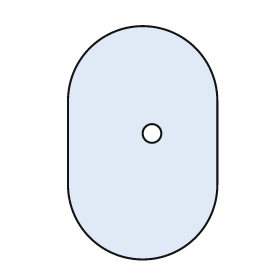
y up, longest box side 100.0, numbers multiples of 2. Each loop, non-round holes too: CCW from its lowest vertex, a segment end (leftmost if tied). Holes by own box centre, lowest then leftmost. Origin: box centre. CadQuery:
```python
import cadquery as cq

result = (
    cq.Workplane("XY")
    .moveTo(-32.0, -18.0)
    .threePointArc((0.0, -50.0), (32.0, -18.0))
    .lineTo(32.0, 18.0)
    .threePointArc((0.0, 50.0), (-32.0, 18.0))
    .close()
    .moveTo(4.0, 4.0)
    .circle(4.0)
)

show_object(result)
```